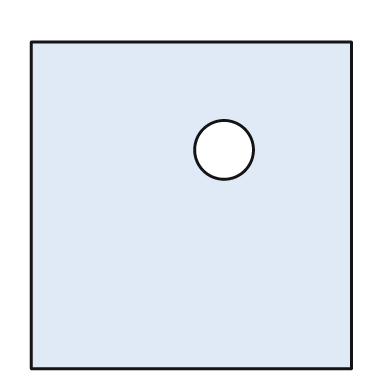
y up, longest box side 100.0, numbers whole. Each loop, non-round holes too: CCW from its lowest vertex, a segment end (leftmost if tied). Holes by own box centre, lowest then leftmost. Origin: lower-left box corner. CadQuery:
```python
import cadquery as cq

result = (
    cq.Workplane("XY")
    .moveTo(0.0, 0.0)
    .lineTo(98.0, 0.0)
    .lineTo(98.0, 100.0)
    .lineTo(0.0, 100.0)
    .close()
    .moveTo(59.0, 67.0)
    .circle(9.0)
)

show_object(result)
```